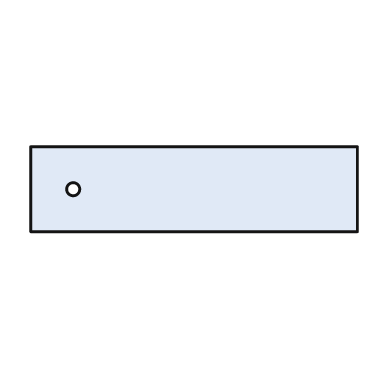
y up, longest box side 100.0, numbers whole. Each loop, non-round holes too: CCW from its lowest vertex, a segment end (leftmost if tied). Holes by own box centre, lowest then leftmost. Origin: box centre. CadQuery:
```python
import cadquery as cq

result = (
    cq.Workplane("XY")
    .moveTo(-50.0, -13.0)
    .lineTo(50.0, -13.0)
    .lineTo(50.0, 13.0)
    .lineTo(-50.0, 13.0)
    .close()
    .moveTo(-37.0, 0.0)
    .circle(2.0)
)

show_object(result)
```